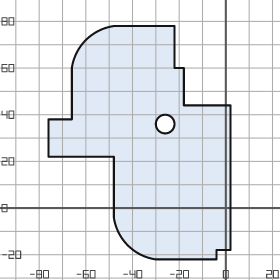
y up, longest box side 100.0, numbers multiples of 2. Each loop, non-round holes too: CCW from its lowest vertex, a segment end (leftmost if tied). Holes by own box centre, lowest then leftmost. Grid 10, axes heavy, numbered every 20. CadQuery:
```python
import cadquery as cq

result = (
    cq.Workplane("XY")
    .moveTo(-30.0, -22.0)
    .lineTo(-4.0, -22.0)
    .lineTo(-4.0, -18.0)
    .lineTo(2.0, -18.0)
    .lineTo(2.0, 44.0)
    .lineTo(-18.0, 44.0)
    .lineTo(-18.0, 60.0)
    .lineTo(-22.0, 60.0)
    .lineTo(-22.0, 78.0)
    .lineTo(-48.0, 78.0)
    .threePointArc((-60.0, 72.0), (-66.0, 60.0))
    .lineTo(-66.0, 38.0)
    .lineTo(-76.0, 38.0)
    .lineTo(-76.0, 22.0)
    .lineTo(-48.0, 22.0)
    .lineTo(-48.0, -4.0)
    .threePointArc((-42.0, -16.0), (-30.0, -22.0))
    .close()
    .moveTo(-26.0, 36.0)
    .circle(4.0)
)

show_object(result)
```